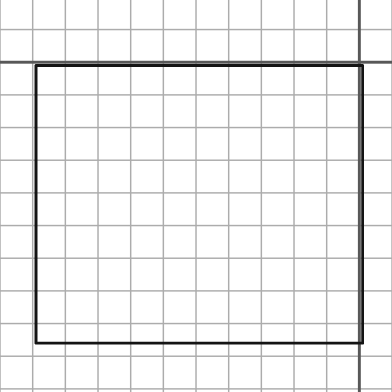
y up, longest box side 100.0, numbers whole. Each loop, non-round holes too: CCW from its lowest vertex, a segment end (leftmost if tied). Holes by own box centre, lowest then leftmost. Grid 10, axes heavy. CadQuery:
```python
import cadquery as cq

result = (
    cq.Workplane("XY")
    .moveTo(-99.0, -86.0)
    .lineTo(1.0, -86.0)
    .lineTo(1.0, -1.0)
    .lineTo(-99.0, -1.0)
    .close()
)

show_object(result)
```